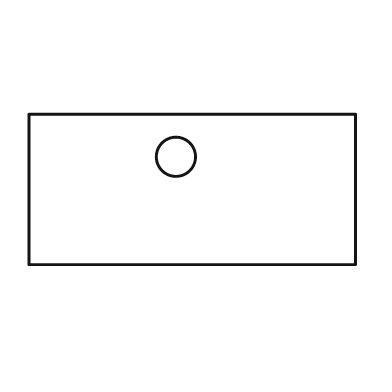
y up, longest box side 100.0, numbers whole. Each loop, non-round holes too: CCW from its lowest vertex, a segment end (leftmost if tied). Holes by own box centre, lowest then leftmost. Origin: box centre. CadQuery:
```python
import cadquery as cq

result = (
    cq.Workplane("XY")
    .moveTo(-50.0, -23.0)
    .lineTo(50.0, -23.0)
    .lineTo(50.0, 23.0)
    .lineTo(-50.0, 23.0)
    .close()
    .moveTo(-5.0, 10.0)
    .circle(6.0)
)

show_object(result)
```